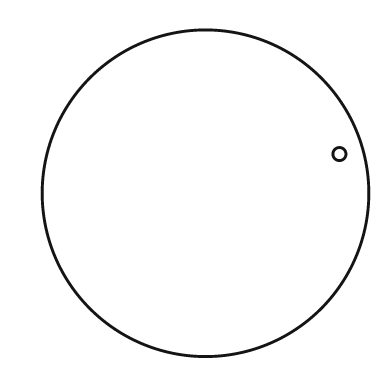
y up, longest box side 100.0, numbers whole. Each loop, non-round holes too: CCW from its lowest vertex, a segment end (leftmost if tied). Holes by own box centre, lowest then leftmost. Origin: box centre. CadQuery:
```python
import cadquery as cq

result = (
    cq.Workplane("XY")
    .moveTo(0.0, 0.0)
    .circle(50.0)
    .moveTo(41.0, 12.0)
    .circle(2.0)
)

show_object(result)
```